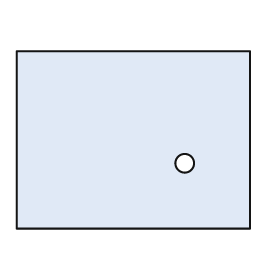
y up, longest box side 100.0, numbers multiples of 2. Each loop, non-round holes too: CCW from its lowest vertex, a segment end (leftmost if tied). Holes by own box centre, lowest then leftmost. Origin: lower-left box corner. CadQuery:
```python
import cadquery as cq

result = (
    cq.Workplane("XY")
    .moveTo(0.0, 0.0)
    .lineTo(100.0, 0.0)
    .lineTo(100.0, 76.0)
    .lineTo(0.0, 76.0)
    .close()
    .moveTo(72.0, 28.0)
    .circle(4.0)
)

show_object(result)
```